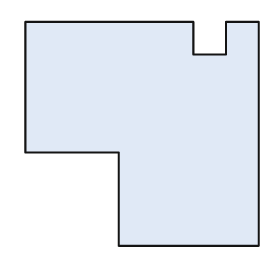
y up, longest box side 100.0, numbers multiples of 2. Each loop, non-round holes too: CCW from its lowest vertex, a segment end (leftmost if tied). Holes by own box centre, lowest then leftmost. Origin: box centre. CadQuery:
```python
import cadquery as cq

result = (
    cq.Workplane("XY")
    .moveTo(-10.0, -48.0)
    .lineTo(50.0, -48.0)
    .lineTo(50.0, 48.0)
    .lineTo(36.0, 48.0)
    .lineTo(36.0, 34.0)
    .lineTo(22.0, 34.0)
    .lineTo(22.0, 48.0)
    .lineTo(-50.0, 48.0)
    .lineTo(-50.0, -8.0)
    .lineTo(-10.0, -8.0)
    .close()
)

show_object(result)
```